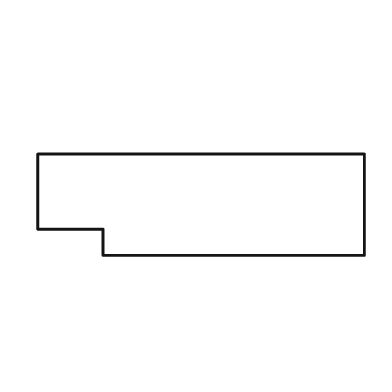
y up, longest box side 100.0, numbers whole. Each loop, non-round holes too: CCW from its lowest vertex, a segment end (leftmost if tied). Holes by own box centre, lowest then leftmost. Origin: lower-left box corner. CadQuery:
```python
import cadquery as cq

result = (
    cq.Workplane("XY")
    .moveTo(20.0, 0.0)
    .lineTo(100.0, 0.0)
    .lineTo(100.0, 31.0)
    .lineTo(0.0, 31.0)
    .lineTo(0.0, 8.0)
    .lineTo(20.0, 8.0)
    .close()
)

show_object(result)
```